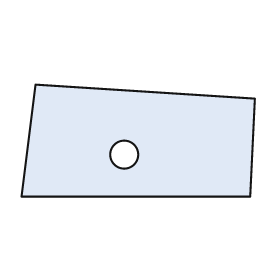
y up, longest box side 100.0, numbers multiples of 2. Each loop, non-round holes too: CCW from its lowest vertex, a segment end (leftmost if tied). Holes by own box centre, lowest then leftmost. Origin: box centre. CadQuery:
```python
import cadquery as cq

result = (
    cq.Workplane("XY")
    .moveTo(-50.0, -24.0)
    .lineTo(48.0, -24.0)
    .lineTo(50.0, 18.0)
    .lineTo(-44.0, 24.0)
    .close()
    .moveTo(-6.0, -6.0)
    .circle(6.0)
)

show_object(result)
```